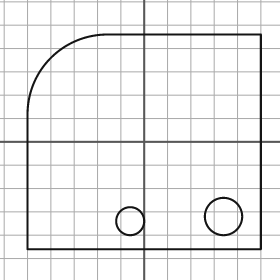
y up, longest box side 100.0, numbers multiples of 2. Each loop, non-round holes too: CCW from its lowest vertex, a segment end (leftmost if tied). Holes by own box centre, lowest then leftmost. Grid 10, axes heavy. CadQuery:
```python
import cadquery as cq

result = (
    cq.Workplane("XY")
    .moveTo(-50.0, -46.0)
    .lineTo(50.0, -46.0)
    .lineTo(50.0, 46.0)
    .lineTo(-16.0, 46.0)
    .threePointArc((-40.0, 36.0), (-50.0, 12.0))
    .close()
    .moveTo(-6.0, -34.0)
    .circle(6.0)
    .moveTo(34.0, -32.0)
    .circle(8.0)
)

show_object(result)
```